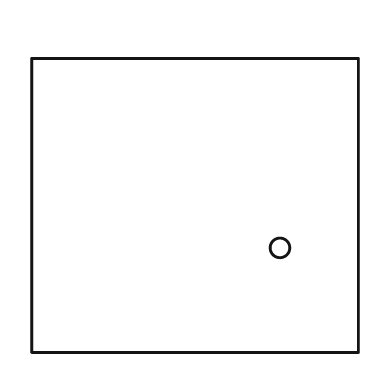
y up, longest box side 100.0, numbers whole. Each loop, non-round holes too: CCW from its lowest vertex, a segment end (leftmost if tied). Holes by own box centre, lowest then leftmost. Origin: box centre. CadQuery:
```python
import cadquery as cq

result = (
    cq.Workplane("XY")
    .moveTo(-50.0, -45.0)
    .lineTo(50.0, -45.0)
    .lineTo(50.0, 45.0)
    .lineTo(-50.0, 45.0)
    .close()
    .moveTo(26.0, -13.0)
    .circle(3.0)
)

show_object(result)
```